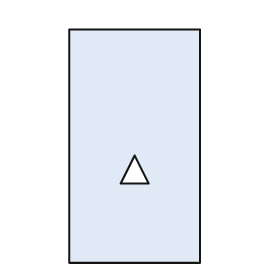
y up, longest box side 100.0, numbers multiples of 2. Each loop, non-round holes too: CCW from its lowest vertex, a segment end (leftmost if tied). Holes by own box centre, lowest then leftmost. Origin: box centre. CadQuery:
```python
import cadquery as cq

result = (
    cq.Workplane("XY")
    .moveTo(-28.0, -50.0)
    .lineTo(28.0, -50.0)
    .lineTo(28.0, 50.0)
    .lineTo(-28.0, 50.0)
    .close()
    .moveTo(-6.0, -16.0)
    .lineTo(6.0, -16.0)
    .lineTo(0.0, -4.0)
    .close()
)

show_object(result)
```